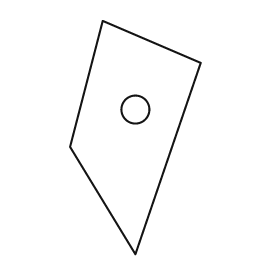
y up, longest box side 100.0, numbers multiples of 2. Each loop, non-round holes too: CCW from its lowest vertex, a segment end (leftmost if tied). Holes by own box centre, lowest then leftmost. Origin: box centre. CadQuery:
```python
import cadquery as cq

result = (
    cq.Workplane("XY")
    .moveTo(0.0, -50.0)
    .lineTo(28.0, 32.0)
    .lineTo(-14.0, 50.0)
    .lineTo(-28.0, -4.0)
    .close()
    .moveTo(0.0, 12.0)
    .circle(6.0)
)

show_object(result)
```